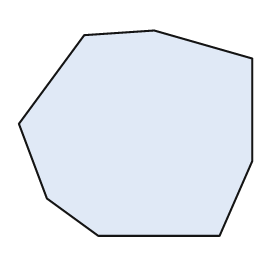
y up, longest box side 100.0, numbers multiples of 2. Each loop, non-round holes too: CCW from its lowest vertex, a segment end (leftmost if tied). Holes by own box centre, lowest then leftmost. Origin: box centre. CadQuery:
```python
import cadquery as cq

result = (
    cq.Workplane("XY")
    .moveTo(-16.0, -44.0)
    .lineTo(36.0, -44.0)
    .lineTo(50.0, -12.0)
    .lineTo(50.0, 32.0)
    .lineTo(8.0, 44.0)
    .lineTo(-22.0, 42.0)
    .lineTo(-50.0, 4.0)
    .lineTo(-38.0, -28.0)
    .close()
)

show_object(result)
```